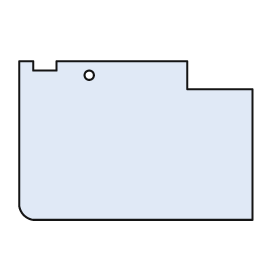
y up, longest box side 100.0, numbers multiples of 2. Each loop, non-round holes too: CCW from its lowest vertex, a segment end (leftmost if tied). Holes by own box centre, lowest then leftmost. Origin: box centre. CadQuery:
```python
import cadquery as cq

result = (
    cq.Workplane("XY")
    .moveTo(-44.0, -34.0)
    .lineTo(50.0, -34.0)
    .lineTo(50.0, 22.0)
    .lineTo(22.0, 22.0)
    .lineTo(22.0, 34.0)
    .lineTo(-34.0, 34.0)
    .lineTo(-34.0, 30.0)
    .lineTo(-44.0, 30.0)
    .lineTo(-44.0, 34.0)
    .lineTo(-50.0, 34.0)
    .lineTo(-50.0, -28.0)
    .threePointArc((-48.0, -32.0), (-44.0, -34.0))
    .close()
    .moveTo(-20.0, 28.0)
    .circle(2.0)
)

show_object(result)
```